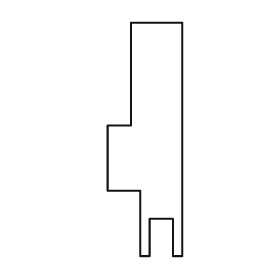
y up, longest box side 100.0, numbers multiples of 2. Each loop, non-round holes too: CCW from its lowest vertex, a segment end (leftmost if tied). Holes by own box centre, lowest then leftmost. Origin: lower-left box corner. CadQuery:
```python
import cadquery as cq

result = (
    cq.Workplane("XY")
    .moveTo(14.0, 0.0)
    .lineTo(18.0, 0.0)
    .lineTo(18.0, 16.0)
    .lineTo(28.0, 16.0)
    .lineTo(28.0, 0.0)
    .lineTo(32.0, 0.0)
    .lineTo(32.0, 100.0)
    .lineTo(10.0, 100.0)
    .lineTo(10.0, 56.0)
    .lineTo(0.0, 56.0)
    .lineTo(0.0, 28.0)
    .lineTo(14.0, 28.0)
    .close()
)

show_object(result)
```